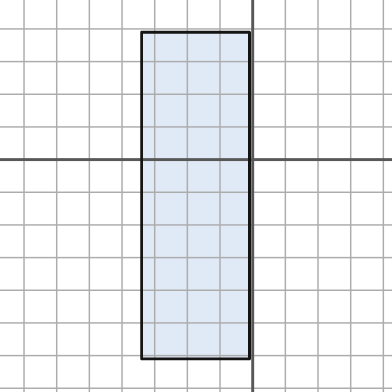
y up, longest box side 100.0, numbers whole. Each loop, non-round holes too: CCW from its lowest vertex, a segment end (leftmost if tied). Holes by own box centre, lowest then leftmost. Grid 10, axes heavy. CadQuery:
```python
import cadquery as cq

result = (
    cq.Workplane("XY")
    .moveTo(-34.0, -61.0)
    .lineTo(-1.0, -61.0)
    .lineTo(-1.0, 39.0)
    .lineTo(-34.0, 39.0)
    .close()
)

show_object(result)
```